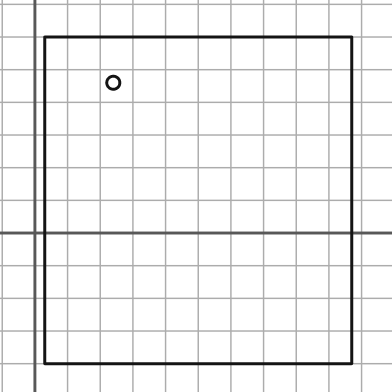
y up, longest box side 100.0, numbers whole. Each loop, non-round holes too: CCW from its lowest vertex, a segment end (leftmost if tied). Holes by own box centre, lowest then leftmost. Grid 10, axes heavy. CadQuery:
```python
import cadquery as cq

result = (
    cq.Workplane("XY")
    .moveTo(3.0, -40.0)
    .lineTo(97.0, -40.0)
    .lineTo(97.0, 60.0)
    .lineTo(3.0, 60.0)
    .close()
    .moveTo(24.0, 46.0)
    .circle(2.0)
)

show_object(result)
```